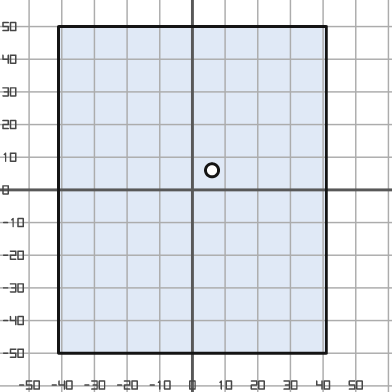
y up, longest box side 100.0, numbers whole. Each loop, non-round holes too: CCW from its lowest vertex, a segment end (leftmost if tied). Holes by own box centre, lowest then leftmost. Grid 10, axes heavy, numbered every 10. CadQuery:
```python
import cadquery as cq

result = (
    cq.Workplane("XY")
    .moveTo(-41.0, -50.0)
    .lineTo(41.0, -50.0)
    .lineTo(41.0, 50.0)
    .lineTo(-41.0, 50.0)
    .close()
    .moveTo(6.0, 6.0)
    .circle(2.0)
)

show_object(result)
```